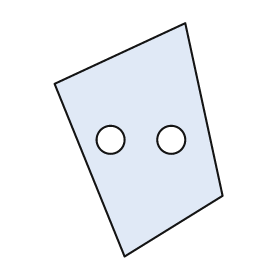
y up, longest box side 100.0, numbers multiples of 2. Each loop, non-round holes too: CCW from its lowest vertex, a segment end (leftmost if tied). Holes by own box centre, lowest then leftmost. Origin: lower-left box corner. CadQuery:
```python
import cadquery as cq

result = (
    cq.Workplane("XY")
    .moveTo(30.0, 0.0)
    .lineTo(72.0, 26.0)
    .lineTo(56.0, 100.0)
    .lineTo(0.0, 74.0)
    .close()
    .moveTo(24.0, 50.0)
    .circle(6.0)
    .moveTo(50.0, 50.0)
    .circle(6.0)
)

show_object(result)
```